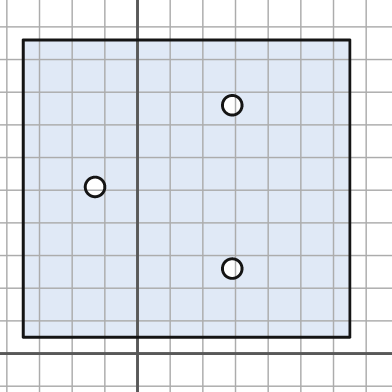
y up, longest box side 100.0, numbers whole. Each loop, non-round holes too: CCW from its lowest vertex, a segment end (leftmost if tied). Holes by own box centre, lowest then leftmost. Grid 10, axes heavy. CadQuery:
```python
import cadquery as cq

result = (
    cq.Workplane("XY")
    .moveTo(-35.0, 5.0)
    .lineTo(65.0, 5.0)
    .lineTo(65.0, 96.0)
    .lineTo(-35.0, 96.0)
    .close()
    .moveTo(29.0, 26.0)
    .circle(3.0)
    .moveTo(-13.0, 51.0)
    .circle(3.0)
    .moveTo(29.0, 76.0)
    .circle(3.0)
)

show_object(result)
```